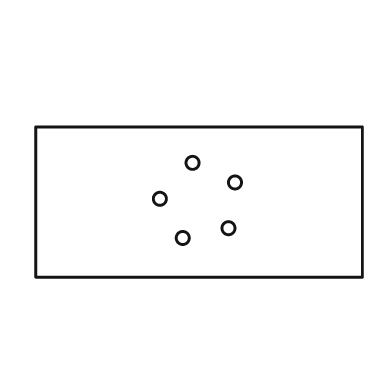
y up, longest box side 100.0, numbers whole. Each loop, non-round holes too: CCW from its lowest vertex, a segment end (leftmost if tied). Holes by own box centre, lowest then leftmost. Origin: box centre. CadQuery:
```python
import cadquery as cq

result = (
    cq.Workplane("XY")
    .moveTo(-50.0, -23.0)
    .lineTo(50.0, -23.0)
    .lineTo(50.0, 23.0)
    .lineTo(-50.0, 23.0)
    .close()
    .moveTo(-5.0, -11.0)
    .circle(2.0)
    .moveTo(9.0, -8.0)
    .circle(2.0)
    .moveTo(-12.0, 1.0)
    .circle(2.0)
    .moveTo(11.0, 6.0)
    .circle(2.0)
    .moveTo(-2.0, 12.0)
    .circle(2.0)
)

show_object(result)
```